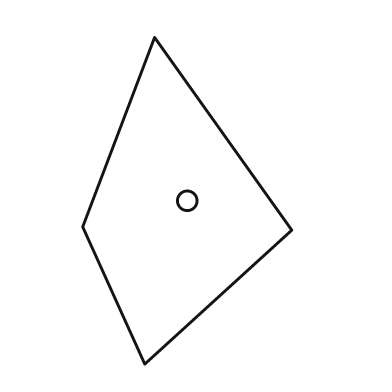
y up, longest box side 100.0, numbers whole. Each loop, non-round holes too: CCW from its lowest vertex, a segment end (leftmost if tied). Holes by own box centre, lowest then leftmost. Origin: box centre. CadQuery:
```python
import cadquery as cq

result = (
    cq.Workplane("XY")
    .moveTo(-13.0, -50.0)
    .lineTo(32.0, -9.0)
    .lineTo(-10.0, 50.0)
    .lineTo(-32.0, -8.0)
    .close()
    .moveTo(0.0, 0.0)
    .circle(3.0)
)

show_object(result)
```